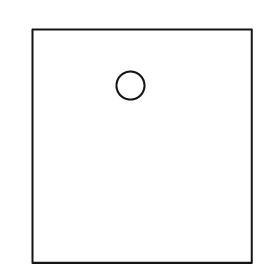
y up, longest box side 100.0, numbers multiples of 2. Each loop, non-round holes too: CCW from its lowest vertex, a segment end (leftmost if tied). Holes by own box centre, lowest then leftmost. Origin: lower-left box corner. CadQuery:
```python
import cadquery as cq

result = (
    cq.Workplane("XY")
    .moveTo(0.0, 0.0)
    .lineTo(94.0, 0.0)
    .lineTo(94.0, 100.0)
    .lineTo(0.0, 100.0)
    .close()
    .moveTo(42.0, 76.0)
    .circle(6.0)
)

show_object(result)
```